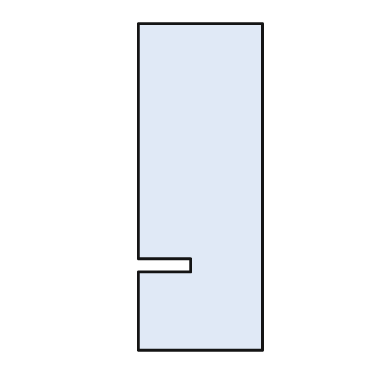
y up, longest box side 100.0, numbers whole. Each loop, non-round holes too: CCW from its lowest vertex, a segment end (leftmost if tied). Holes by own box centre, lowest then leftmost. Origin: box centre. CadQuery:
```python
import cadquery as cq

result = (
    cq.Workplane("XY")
    .moveTo(-19.0, -50.0)
    .lineTo(19.0, -50.0)
    .lineTo(19.0, 50.0)
    .lineTo(-19.0, 50.0)
    .lineTo(-19.0, -22.0)
    .lineTo(-3.0, -22.0)
    .lineTo(-3.0, -26.0)
    .lineTo(-19.0, -26.0)
    .close()
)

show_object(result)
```